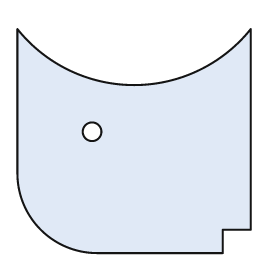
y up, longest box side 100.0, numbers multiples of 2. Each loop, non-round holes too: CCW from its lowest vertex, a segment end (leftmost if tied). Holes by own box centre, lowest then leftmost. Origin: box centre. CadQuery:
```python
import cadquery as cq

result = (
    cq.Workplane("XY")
    .moveTo(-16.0, -48.0)
    .lineTo(38.0, -48.0)
    .lineTo(38.0, -38.0)
    .lineTo(50.0, -38.0)
    .lineTo(50.0, 48.0)
    .threePointArc((0.0, 24.0), (-50.0, 48.0))
    .lineTo(-50.0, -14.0)
    .threePointArc((-40.0, -38.0), (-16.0, -48.0))
    .close()
    .moveTo(-18.0, 4.0)
    .circle(4.0)
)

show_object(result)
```